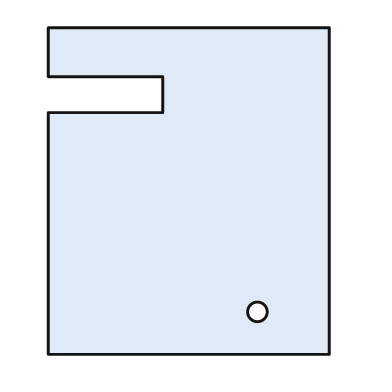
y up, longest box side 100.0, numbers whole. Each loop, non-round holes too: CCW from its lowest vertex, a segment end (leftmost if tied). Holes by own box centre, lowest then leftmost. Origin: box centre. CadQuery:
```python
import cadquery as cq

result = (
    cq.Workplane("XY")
    .moveTo(-43.0, -50.0)
    .lineTo(43.0, -50.0)
    .lineTo(43.0, 50.0)
    .lineTo(-43.0, 50.0)
    .lineTo(-43.0, 35.0)
    .lineTo(-8.0, 35.0)
    .lineTo(-8.0, 24.0)
    .lineTo(-43.0, 24.0)
    .close()
    .moveTo(21.0, -37.0)
    .circle(3.0)
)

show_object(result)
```